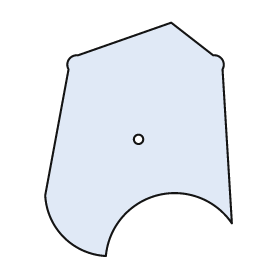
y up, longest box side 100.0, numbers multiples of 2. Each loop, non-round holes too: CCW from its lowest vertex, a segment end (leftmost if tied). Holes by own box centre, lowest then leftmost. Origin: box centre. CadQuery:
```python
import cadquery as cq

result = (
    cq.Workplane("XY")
    .moveTo(-14.0, -50.0)
    .threePointArc((8.0, -24.0), (40.0, -36.0))
    .lineTo(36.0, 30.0)
    .threePointArc((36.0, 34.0), (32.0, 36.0))
    .lineTo(14.0, 50.0)
    .lineTo(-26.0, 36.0)
    .threePointArc((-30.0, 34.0), (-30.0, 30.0))
    .lineTo(-40.0, -24.0)
    .threePointArc((-32.0, -42.0), (-14.0, -50.0))
    .close()
    .moveTo(0.0, 0.0)
    .circle(2.0)
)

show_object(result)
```